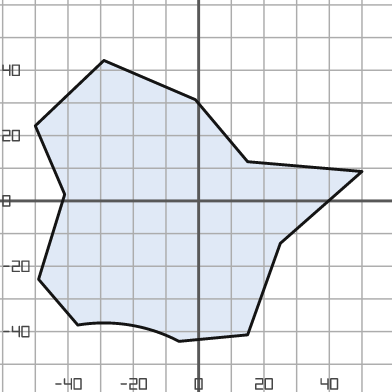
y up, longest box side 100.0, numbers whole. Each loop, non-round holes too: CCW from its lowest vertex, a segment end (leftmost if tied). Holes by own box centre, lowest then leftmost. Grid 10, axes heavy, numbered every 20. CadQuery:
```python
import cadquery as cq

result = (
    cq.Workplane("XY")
    .moveTo(-6.0, -43.0)
    .lineTo(15.0, -41.0)
    .lineTo(25.0, -13.0)
    .lineTo(50.0, 9.0)
    .lineTo(15.0, 12.0)
    .lineTo(-1.0, 31.0)
    .lineTo(-29.0, 43.0)
    .lineTo(-50.0, 23.0)
    .lineTo(-41.0, 2.0)
    .lineTo(-49.0, -24.0)
    .lineTo(-37.0, -38.0)
    .threePointArc((-21.0, -38.0), (-6.0, -43.0))
    .close()
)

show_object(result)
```